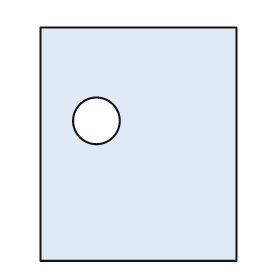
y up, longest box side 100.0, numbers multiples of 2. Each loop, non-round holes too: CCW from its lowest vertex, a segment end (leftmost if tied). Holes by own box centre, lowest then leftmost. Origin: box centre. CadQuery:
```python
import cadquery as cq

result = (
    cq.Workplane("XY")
    .moveTo(-42.0, -50.0)
    .lineTo(42.0, -50.0)
    .lineTo(42.0, 50.0)
    .lineTo(-42.0, 50.0)
    .close()
    .moveTo(-18.0, 10.0)
    .circle(10.0)
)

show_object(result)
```